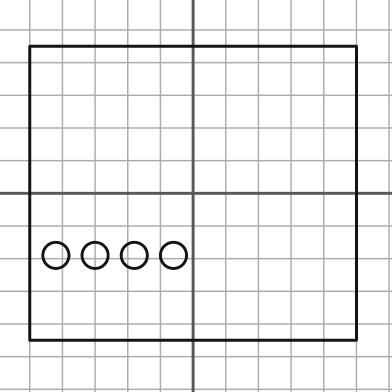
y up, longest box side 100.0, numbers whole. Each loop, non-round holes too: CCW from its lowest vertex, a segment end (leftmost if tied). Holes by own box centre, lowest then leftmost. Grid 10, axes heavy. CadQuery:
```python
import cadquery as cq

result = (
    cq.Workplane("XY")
    .moveTo(-50.0, -45.0)
    .lineTo(50.0, -45.0)
    .lineTo(50.0, 45.0)
    .lineTo(-50.0, 45.0)
    .close()
    .moveTo(-42.0, -19.0)
    .circle(4.0)
    .moveTo(-30.0, -19.0)
    .circle(4.0)
    .moveTo(-18.0, -19.0)
    .circle(4.0)
    .moveTo(-6.0, -19.0)
    .circle(4.0)
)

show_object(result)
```